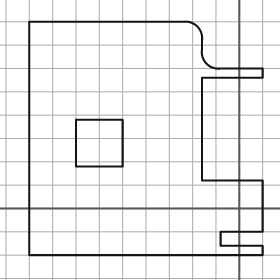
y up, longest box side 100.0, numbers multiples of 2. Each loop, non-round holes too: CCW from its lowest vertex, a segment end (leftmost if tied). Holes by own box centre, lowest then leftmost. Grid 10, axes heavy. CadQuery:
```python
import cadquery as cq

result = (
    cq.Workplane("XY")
    .moveTo(-90.0, -20.0)
    .lineTo(10.0, -20.0)
    .lineTo(10.0, -16.0)
    .lineTo(-8.0, -16.0)
    .lineTo(-8.0, -10.0)
    .lineTo(10.0, -10.0)
    .lineTo(10.0, 12.0)
    .lineTo(-16.0, 12.0)
    .lineTo(-16.0, 56.0)
    .lineTo(10.0, 56.0)
    .lineTo(10.0, 60.0)
    .lineTo(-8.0, 60.0)
    .threePointArc((-14.0, 62.0), (-16.0, 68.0))
    .lineTo(-16.0, 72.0)
    .threePointArc((-18.0, 78.0), (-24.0, 80.0))
    .lineTo(-90.0, 80.0)
    .close()
    .moveTo(-70.0, 18.0)
    .lineTo(-50.0, 18.0)
    .lineTo(-50.0, 38.0)
    .lineTo(-70.0, 38.0)
    .close()
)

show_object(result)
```